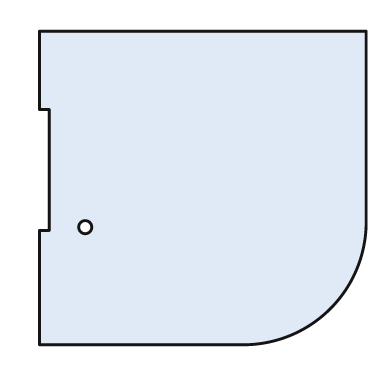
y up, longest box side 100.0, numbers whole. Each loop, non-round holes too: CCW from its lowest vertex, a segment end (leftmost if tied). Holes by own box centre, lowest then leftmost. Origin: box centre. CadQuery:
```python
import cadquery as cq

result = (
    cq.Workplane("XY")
    .moveTo(-50.0, -48.0)
    .lineTo(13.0, -48.0)
    .threePointArc((39.0, -37.0), (50.0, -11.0))
    .lineTo(50.0, 48.0)
    .lineTo(-50.0, 48.0)
    .lineTo(-50.0, 24.0)
    .lineTo(-47.0, 24.0)
    .lineTo(-47.0, -13.0)
    .lineTo(-50.0, -13.0)
    .close()
    .moveTo(-36.0, -12.0)
    .circle(2.0)
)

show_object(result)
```